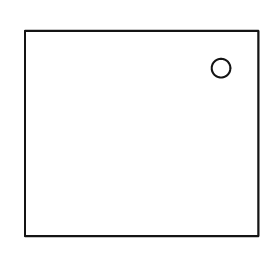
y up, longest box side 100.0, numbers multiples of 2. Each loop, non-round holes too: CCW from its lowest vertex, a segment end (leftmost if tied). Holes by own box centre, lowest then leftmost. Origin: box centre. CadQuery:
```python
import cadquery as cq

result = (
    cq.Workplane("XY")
    .moveTo(-50.0, -44.0)
    .lineTo(50.0, -44.0)
    .lineTo(50.0, 44.0)
    .lineTo(-50.0, 44.0)
    .close()
    .moveTo(34.0, 28.0)
    .circle(4.0)
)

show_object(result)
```